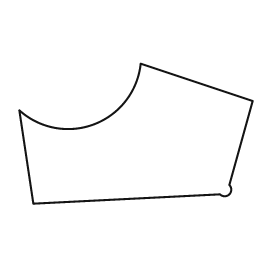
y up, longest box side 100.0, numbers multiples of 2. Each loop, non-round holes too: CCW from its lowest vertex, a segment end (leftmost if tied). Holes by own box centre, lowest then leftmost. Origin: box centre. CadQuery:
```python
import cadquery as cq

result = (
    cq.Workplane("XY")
    .moveTo(-44.0, -30.0)
    .lineTo(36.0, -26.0)
    .threePointArc((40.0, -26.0), (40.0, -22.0))
    .lineTo(50.0, 14.0)
    .lineTo(2.0, 30.0)
    .threePointArc((-18.0, 4.0), (-50.0, 10.0))
    .close()
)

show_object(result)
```